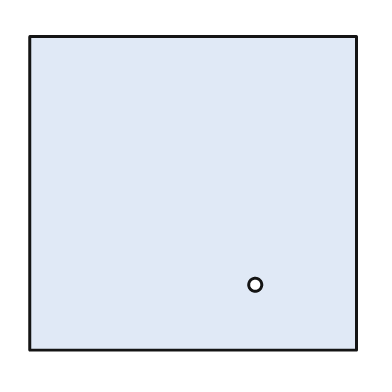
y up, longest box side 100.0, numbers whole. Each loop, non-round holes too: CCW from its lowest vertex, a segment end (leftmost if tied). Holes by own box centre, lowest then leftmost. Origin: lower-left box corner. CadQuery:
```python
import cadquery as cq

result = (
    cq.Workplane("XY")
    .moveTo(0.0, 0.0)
    .lineTo(100.0, 0.0)
    .lineTo(100.0, 96.0)
    .lineTo(0.0, 96.0)
    .close()
    .moveTo(69.0, 20.0)
    .circle(2.0)
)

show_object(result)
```